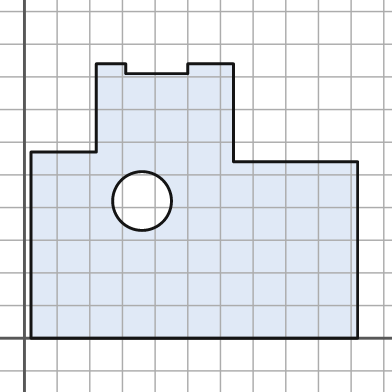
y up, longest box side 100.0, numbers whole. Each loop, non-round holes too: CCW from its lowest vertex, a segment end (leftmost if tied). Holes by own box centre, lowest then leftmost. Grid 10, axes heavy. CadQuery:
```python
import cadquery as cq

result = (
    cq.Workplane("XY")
    .moveTo(2.0, 0.0)
    .lineTo(102.0, 0.0)
    .lineTo(102.0, 54.0)
    .lineTo(64.0, 54.0)
    .lineTo(64.0, 84.0)
    .lineTo(50.0, 84.0)
    .lineTo(50.0, 81.0)
    .lineTo(31.0, 81.0)
    .lineTo(31.0, 84.0)
    .lineTo(22.0, 84.0)
    .lineTo(22.0, 57.0)
    .lineTo(2.0, 57.0)
    .close()
    .moveTo(36.0, 42.0)
    .circle(9.0)
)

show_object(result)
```